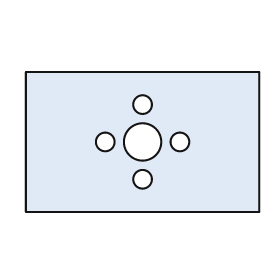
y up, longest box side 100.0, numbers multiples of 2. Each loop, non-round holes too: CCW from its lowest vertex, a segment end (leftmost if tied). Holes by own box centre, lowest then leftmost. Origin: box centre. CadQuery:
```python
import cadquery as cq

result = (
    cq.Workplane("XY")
    .moveTo(-50.0, -30.0)
    .lineTo(50.0, -30.0)
    .lineTo(50.0, 30.0)
    .lineTo(-50.0, 30.0)
    .close()
    .moveTo(0.0, -16.0)
    .circle(4.0)
    .moveTo(-16.0, 0.0)
    .circle(4.0)
    .moveTo(0.0, 0.0)
    .circle(8.0)
    .moveTo(16.0, 0.0)
    .circle(4.0)
    .moveTo(0.0, 16.0)
    .circle(4.0)
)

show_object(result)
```